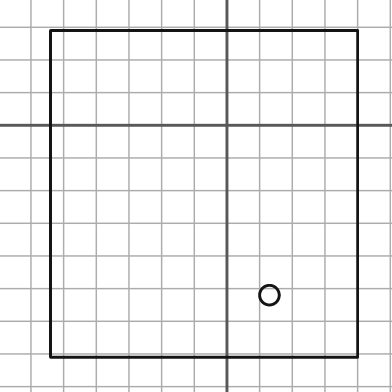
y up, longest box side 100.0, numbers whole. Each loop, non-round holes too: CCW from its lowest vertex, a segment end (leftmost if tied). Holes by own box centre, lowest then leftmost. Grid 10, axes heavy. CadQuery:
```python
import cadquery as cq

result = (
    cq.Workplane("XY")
    .moveTo(-54.0, -71.0)
    .lineTo(40.0, -71.0)
    .lineTo(40.0, 29.0)
    .lineTo(-54.0, 29.0)
    .close()
    .moveTo(13.0, -52.0)
    .circle(3.0)
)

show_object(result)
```